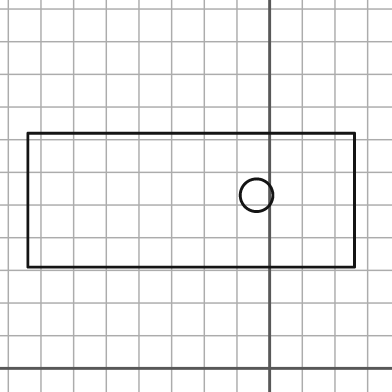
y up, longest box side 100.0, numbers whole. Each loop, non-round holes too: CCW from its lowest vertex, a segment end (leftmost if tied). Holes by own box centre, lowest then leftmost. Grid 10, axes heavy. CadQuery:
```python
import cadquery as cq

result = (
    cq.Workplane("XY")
    .moveTo(-74.0, 31.0)
    .lineTo(26.0, 31.0)
    .lineTo(26.0, 72.0)
    .lineTo(-74.0, 72.0)
    .close()
    .moveTo(-4.0, 53.0)
    .circle(5.0)
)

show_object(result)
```